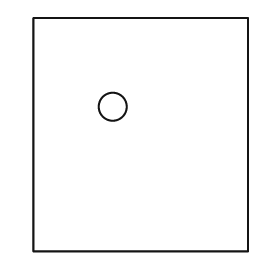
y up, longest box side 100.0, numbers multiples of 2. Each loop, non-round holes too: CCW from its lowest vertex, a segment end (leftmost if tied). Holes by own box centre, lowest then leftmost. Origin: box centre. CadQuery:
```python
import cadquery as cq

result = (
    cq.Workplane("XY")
    .moveTo(-46.0, -50.0)
    .lineTo(46.0, -50.0)
    .lineTo(46.0, 50.0)
    .lineTo(-46.0, 50.0)
    .close()
    .moveTo(-12.0, 12.0)
    .circle(6.0)
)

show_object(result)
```